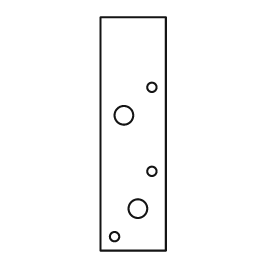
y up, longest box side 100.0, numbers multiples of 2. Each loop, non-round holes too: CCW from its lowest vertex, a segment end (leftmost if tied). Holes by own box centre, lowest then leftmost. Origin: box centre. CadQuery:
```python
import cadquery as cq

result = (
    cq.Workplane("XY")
    .moveTo(-14.0, -50.0)
    .lineTo(14.0, -50.0)
    .lineTo(14.0, 50.0)
    .lineTo(-14.0, 50.0)
    .close()
    .moveTo(-8.0, -44.0)
    .circle(2.0)
    .moveTo(2.0, -32.0)
    .circle(4.0)
    .moveTo(8.0, -16.0)
    .circle(2.0)
    .moveTo(-4.0, 8.0)
    .circle(4.0)
    .moveTo(8.0, 20.0)
    .circle(2.0)
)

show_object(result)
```